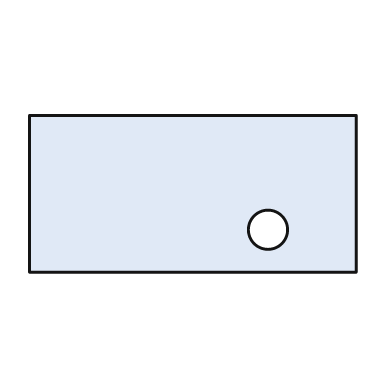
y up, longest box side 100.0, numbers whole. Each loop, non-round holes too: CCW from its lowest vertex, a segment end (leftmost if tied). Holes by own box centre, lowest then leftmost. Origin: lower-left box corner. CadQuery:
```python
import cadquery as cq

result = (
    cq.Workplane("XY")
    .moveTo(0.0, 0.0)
    .lineTo(100.0, 0.0)
    .lineTo(100.0, 48.0)
    .lineTo(0.0, 48.0)
    .close()
    .moveTo(73.0, 13.0)
    .circle(6.0)
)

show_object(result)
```